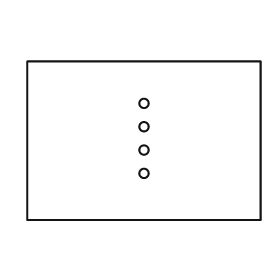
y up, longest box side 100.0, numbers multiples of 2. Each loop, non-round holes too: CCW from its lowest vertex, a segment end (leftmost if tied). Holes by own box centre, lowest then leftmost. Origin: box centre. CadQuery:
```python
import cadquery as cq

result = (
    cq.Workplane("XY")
    .moveTo(-50.0, -34.0)
    .lineTo(50.0, -34.0)
    .lineTo(50.0, 34.0)
    .lineTo(-50.0, 34.0)
    .close()
    .moveTo(0.0, -14.0)
    .circle(2.0)
    .moveTo(0.0, -4.0)
    .circle(2.0)
    .moveTo(0.0, 6.0)
    .circle(2.0)
    .moveTo(0.0, 16.0)
    .circle(2.0)
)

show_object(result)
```